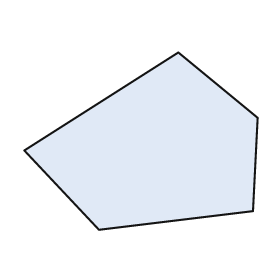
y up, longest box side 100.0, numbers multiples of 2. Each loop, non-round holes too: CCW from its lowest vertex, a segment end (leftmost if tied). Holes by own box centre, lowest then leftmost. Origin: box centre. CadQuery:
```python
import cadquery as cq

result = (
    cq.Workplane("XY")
    .moveTo(-18.0, -38.0)
    .lineTo(48.0, -30.0)
    .lineTo(50.0, 10.0)
    .lineTo(16.0, 38.0)
    .lineTo(-50.0, -4.0)
    .close()
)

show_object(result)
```